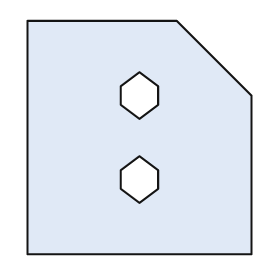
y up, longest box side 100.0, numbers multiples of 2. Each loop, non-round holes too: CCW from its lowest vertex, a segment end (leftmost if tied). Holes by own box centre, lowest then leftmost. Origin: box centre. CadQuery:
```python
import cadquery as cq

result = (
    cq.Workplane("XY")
    .moveTo(-48.0, -50.0)
    .lineTo(48.0, -50.0)
    .lineTo(48.0, 18.0)
    .lineTo(16.0, 50.0)
    .lineTo(-48.0, 50.0)
    .close()
    .moveTo(0.0, -28.0)
    .lineTo(8.0, -22.0)
    .lineTo(8.0, -14.0)
    .lineTo(0.0, -8.0)
    .lineTo(-8.0, -14.0)
    .lineTo(-8.0, -22.0)
    .close()
    .moveTo(0.0, 8.0)
    .lineTo(8.0, 14.0)
    .lineTo(8.0, 22.0)
    .lineTo(0.0, 28.0)
    .lineTo(-8.0, 22.0)
    .lineTo(-8.0, 14.0)
    .close()
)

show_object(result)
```